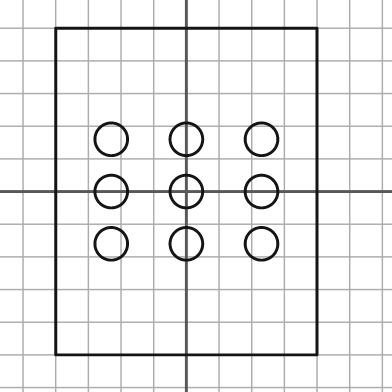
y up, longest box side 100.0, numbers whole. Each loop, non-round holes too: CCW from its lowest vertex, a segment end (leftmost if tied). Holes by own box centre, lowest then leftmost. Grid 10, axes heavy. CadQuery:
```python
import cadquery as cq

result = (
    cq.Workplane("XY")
    .moveTo(-40.0, -50.0)
    .lineTo(40.0, -50.0)
    .lineTo(40.0, 50.0)
    .lineTo(-40.0, 50.0)
    .close()
    .moveTo(-23.0, -16.0)
    .circle(5.0)
    .moveTo(0.0, -16.0)
    .circle(5.0)
    .moveTo(23.0, -16.0)
    .circle(5.0)
    .moveTo(-23.0, 0.0)
    .circle(5.0)
    .moveTo(0.0, 0.0)
    .circle(5.0)
    .moveTo(23.0, 0.0)
    .circle(5.0)
    .moveTo(-23.0, 16.0)
    .circle(5.0)
    .moveTo(0.0, 16.0)
    .circle(5.0)
    .moveTo(23.0, 16.0)
    .circle(5.0)
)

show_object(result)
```